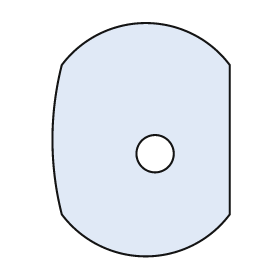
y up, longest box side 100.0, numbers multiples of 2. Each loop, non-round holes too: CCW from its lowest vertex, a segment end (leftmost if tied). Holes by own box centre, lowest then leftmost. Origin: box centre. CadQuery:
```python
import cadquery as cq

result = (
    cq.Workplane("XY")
    .moveTo(-34.0, -32.0)
    .threePointArc((2.0, -50.0), (38.0, -32.0))
    .lineTo(38.0, 32.0)
    .threePointArc((2.0, 50.0), (-34.0, 32.0))
    .threePointArc((-38.0, 0.0), (-34.0, -32.0))
    .close()
    .moveTo(6.0, -6.0)
    .circle(8.0)
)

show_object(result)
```